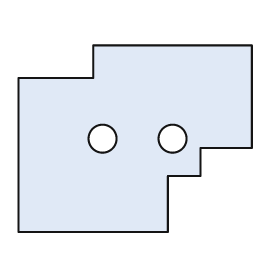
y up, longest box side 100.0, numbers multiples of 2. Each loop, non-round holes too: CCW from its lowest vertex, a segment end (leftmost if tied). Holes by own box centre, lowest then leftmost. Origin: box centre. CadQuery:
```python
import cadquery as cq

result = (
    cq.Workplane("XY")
    .moveTo(-50.0, -40.0)
    .lineTo(14.0, -40.0)
    .lineTo(14.0, -16.0)
    .lineTo(28.0, -16.0)
    .lineTo(28.0, -4.0)
    .lineTo(50.0, -4.0)
    .lineTo(50.0, 40.0)
    .lineTo(-18.0, 40.0)
    .lineTo(-18.0, 26.0)
    .lineTo(-50.0, 26.0)
    .close()
    .moveTo(-14.0, 0.0)
    .circle(6.0)
    .moveTo(16.0, 0.0)
    .circle(6.0)
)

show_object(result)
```